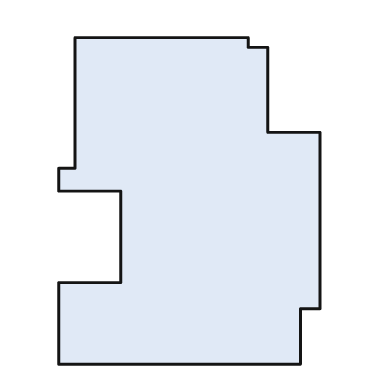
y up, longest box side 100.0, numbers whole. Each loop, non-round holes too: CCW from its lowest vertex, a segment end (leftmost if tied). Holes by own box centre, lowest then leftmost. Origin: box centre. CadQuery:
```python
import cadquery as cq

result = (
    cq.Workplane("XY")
    .moveTo(-40.0, -50.0)
    .lineTo(34.0, -50.0)
    .lineTo(34.0, -33.0)
    .lineTo(40.0, -33.0)
    .lineTo(40.0, 21.0)
    .lineTo(24.0, 21.0)
    .lineTo(24.0, 47.0)
    .lineTo(18.0, 47.0)
    .lineTo(18.0, 50.0)
    .lineTo(-35.0, 50.0)
    .lineTo(-35.0, 10.0)
    .lineTo(-40.0, 10.0)
    .lineTo(-40.0, 3.0)
    .lineTo(-21.0, 3.0)
    .lineTo(-21.0, -25.0)
    .lineTo(-40.0, -25.0)
    .close()
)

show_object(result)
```